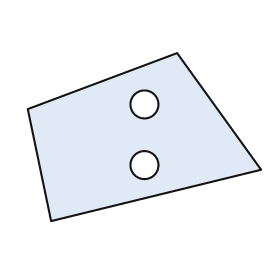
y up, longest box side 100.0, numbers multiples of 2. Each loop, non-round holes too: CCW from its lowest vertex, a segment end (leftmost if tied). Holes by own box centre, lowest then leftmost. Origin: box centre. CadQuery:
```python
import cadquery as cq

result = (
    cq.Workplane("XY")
    .moveTo(-40.0, -36.0)
    .lineTo(50.0, -14.0)
    .lineTo(14.0, 36.0)
    .lineTo(-50.0, 12.0)
    .close()
    .moveTo(0.0, -12.0)
    .circle(6.0)
    .moveTo(0.0, 14.0)
    .circle(6.0)
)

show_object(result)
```